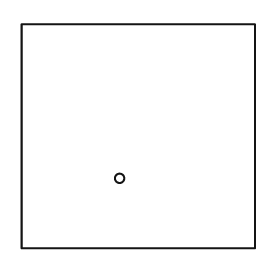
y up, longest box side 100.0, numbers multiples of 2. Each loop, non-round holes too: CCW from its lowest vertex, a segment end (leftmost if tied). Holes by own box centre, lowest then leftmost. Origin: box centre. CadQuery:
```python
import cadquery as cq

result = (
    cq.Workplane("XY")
    .moveTo(-50.0, -48.0)
    .lineTo(50.0, -48.0)
    .lineTo(50.0, 48.0)
    .lineTo(-50.0, 48.0)
    .close()
    .moveTo(-8.0, -18.0)
    .circle(2.0)
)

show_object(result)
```